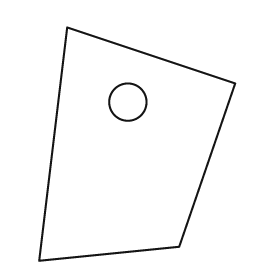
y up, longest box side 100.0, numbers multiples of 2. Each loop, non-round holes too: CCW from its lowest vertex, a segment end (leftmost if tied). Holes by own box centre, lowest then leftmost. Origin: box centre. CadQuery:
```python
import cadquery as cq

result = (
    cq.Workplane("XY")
    .moveTo(-42.0, -50.0)
    .lineTo(18.0, -44.0)
    .lineTo(42.0, 26.0)
    .lineTo(-30.0, 50.0)
    .close()
    .moveTo(-4.0, 18.0)
    .circle(8.0)
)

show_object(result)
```